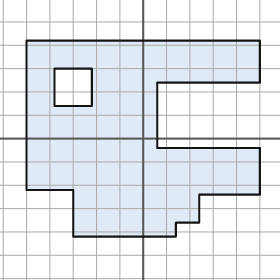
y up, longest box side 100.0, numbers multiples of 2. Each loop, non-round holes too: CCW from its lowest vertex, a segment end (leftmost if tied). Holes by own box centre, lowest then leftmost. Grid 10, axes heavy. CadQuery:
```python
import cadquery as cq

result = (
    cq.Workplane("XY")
    .moveTo(-30.0, -42.0)
    .lineTo(14.0, -42.0)
    .lineTo(14.0, -36.0)
    .lineTo(24.0, -36.0)
    .lineTo(24.0, -24.0)
    .lineTo(50.0, -24.0)
    .lineTo(50.0, -4.0)
    .lineTo(6.0, -4.0)
    .lineTo(6.0, 24.0)
    .lineTo(50.0, 24.0)
    .lineTo(50.0, 42.0)
    .lineTo(-50.0, 42.0)
    .lineTo(-50.0, -22.0)
    .lineTo(-30.0, -22.0)
    .close()
    .moveTo(-38.0, 14.0)
    .lineTo(-22.0, 14.0)
    .lineTo(-22.0, 30.0)
    .lineTo(-38.0, 30.0)
    .close()
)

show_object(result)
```